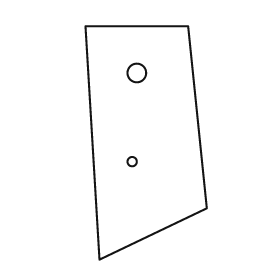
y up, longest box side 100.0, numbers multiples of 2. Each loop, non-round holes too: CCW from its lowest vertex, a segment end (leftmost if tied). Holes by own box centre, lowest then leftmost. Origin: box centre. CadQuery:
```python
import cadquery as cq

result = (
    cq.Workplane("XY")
    .moveTo(-20.0, -50.0)
    .lineTo(26.0, -28.0)
    .lineTo(18.0, 50.0)
    .lineTo(-26.0, 50.0)
    .close()
    .moveTo(-6.0, -8.0)
    .circle(2.0)
    .moveTo(-4.0, 30.0)
    .circle(4.0)
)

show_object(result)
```